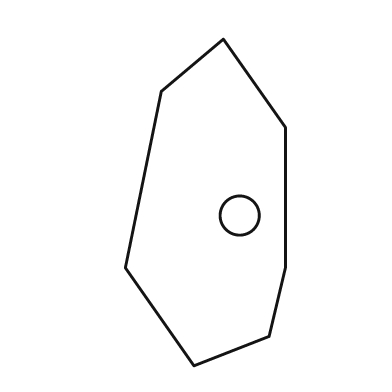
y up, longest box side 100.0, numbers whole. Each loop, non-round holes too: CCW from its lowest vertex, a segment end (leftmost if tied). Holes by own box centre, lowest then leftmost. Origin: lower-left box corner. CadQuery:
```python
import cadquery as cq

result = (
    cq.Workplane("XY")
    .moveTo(21.0, 0.0)
    .lineTo(44.0, 9.0)
    .lineTo(49.0, 30.0)
    .lineTo(49.0, 73.0)
    .lineTo(30.0, 100.0)
    .lineTo(11.0, 84.0)
    .lineTo(0.0, 30.0)
    .close()
    .moveTo(35.0, 46.0)
    .circle(6.0)
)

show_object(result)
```